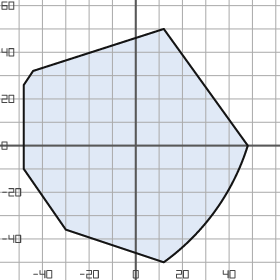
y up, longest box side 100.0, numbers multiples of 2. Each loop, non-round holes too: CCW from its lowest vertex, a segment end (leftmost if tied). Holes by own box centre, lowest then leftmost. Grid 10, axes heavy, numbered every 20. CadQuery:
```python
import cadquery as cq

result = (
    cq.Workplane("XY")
    .moveTo(12.0, -50.0)
    .threePointArc((34.0, -28.0), (48.0, 0.0))
    .lineTo(12.0, 50.0)
    .lineTo(-44.0, 32.0)
    .lineTo(-48.0, 26.0)
    .lineTo(-48.0, -10.0)
    .lineTo(-30.0, -36.0)
    .close()
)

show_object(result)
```